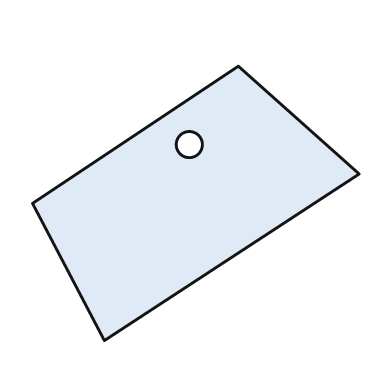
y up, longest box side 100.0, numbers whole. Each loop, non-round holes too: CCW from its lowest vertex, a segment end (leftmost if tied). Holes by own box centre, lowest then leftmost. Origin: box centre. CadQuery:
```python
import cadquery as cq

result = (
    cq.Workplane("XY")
    .moveTo(-28.0, -42.0)
    .lineTo(50.0, 9.0)
    .lineTo(13.0, 42.0)
    .lineTo(-50.0, 0.0)
    .close()
    .moveTo(-2.0, 18.0)
    .circle(4.0)
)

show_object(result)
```